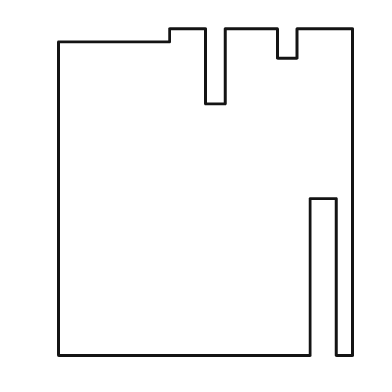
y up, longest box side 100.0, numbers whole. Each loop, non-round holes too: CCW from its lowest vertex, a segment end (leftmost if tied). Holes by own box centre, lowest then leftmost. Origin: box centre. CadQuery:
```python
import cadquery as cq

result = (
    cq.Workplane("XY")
    .moveTo(-45.0, -50.0)
    .lineTo(32.0, -50.0)
    .lineTo(32.0, -2.0)
    .lineTo(40.0, -2.0)
    .lineTo(40.0, -50.0)
    .lineTo(45.0, -50.0)
    .lineTo(45.0, 50.0)
    .lineTo(28.0, 50.0)
    .lineTo(28.0, 41.0)
    .lineTo(22.0, 41.0)
    .lineTo(22.0, 50.0)
    .lineTo(6.0, 50.0)
    .lineTo(6.0, 27.0)
    .lineTo(0.0, 27.0)
    .lineTo(0.0, 50.0)
    .lineTo(-11.0, 50.0)
    .lineTo(-11.0, 46.0)
    .lineTo(-45.0, 46.0)
    .close()
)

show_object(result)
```